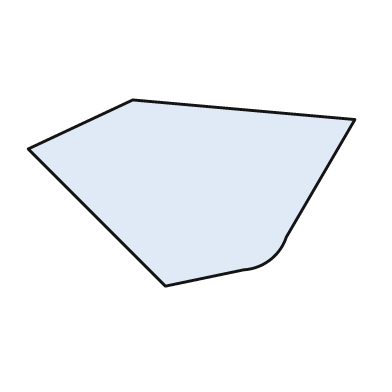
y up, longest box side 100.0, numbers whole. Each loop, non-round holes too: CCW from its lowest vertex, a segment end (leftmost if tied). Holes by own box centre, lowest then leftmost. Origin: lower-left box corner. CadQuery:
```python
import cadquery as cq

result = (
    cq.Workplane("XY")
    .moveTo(42.0, 0.0)
    .lineTo(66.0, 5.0)
    .threePointArc((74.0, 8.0), (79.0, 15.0))
    .lineTo(100.0, 51.0)
    .lineTo(32.0, 57.0)
    .lineTo(0.0, 42.0)
    .close()
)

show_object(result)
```